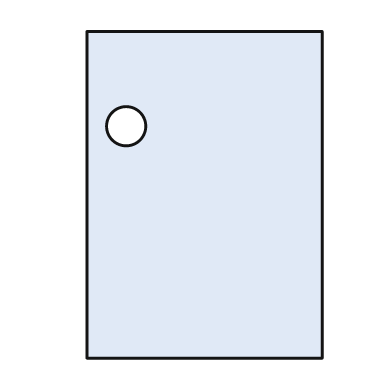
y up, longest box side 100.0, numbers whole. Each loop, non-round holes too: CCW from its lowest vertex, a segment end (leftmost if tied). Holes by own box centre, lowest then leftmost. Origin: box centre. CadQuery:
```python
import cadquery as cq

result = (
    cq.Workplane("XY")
    .moveTo(-36.0, -50.0)
    .lineTo(36.0, -50.0)
    .lineTo(36.0, 50.0)
    .lineTo(-36.0, 50.0)
    .close()
    .moveTo(-24.0, 21.0)
    .circle(6.0)
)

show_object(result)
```